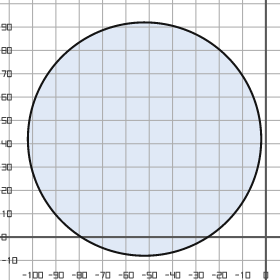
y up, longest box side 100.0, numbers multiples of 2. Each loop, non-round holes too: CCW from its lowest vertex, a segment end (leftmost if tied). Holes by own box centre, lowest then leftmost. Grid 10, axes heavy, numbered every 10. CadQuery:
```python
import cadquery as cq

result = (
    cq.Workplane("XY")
    .moveTo(-52.0, 42.0)
    .circle(50.0)
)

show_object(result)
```